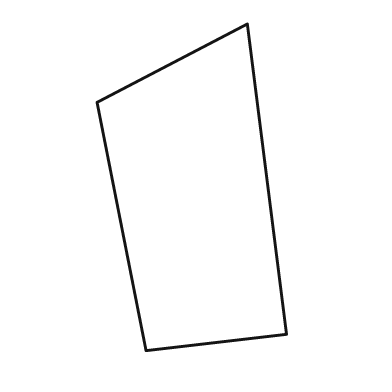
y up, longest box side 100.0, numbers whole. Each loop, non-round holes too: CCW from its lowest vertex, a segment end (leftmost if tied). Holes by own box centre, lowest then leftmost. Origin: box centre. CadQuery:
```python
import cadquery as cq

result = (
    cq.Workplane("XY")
    .moveTo(-14.0, -50.0)
    .lineTo(29.0, -45.0)
    .lineTo(17.0, 50.0)
    .lineTo(-29.0, 26.0)
    .close()
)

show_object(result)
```